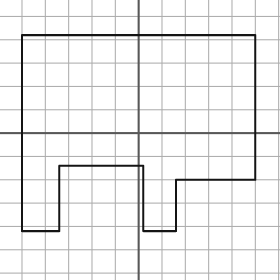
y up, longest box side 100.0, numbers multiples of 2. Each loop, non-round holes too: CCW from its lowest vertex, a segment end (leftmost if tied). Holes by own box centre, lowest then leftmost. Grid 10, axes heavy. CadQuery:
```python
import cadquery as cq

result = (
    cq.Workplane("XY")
    .moveTo(-50.0, -42.0)
    .lineTo(-34.0, -42.0)
    .lineTo(-34.0, -14.0)
    .lineTo(2.0, -14.0)
    .lineTo(2.0, -42.0)
    .lineTo(16.0, -42.0)
    .lineTo(16.0, -20.0)
    .lineTo(50.0, -20.0)
    .lineTo(50.0, 42.0)
    .lineTo(-50.0, 42.0)
    .close()
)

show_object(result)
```